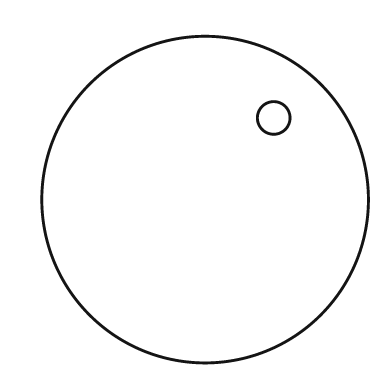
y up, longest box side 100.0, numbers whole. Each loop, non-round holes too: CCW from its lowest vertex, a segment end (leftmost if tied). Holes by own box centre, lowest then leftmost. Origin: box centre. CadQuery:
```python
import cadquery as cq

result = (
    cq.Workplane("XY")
    .moveTo(0.0, 0.0)
    .circle(50.0)
    .moveTo(21.0, 25.0)
    .circle(5.0)
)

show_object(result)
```